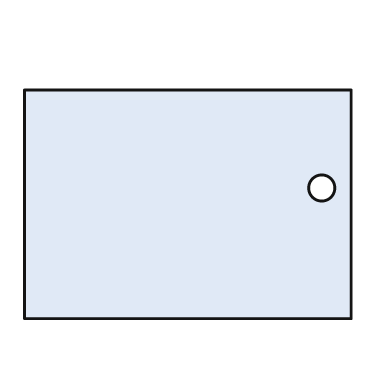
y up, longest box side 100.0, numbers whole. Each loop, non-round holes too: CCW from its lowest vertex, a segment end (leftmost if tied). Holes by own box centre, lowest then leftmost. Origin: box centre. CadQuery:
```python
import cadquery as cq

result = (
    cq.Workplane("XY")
    .moveTo(-50.0, -35.0)
    .lineTo(50.0, -35.0)
    .lineTo(50.0, 35.0)
    .lineTo(-50.0, 35.0)
    .close()
    .moveTo(41.0, 5.0)
    .circle(4.0)
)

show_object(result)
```